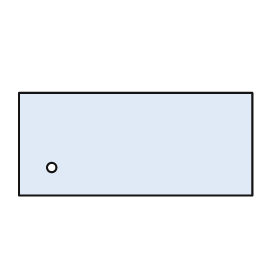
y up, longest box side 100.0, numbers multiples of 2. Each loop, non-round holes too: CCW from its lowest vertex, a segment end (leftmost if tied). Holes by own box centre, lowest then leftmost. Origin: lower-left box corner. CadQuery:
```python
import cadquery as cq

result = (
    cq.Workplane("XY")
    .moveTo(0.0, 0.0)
    .lineTo(100.0, 0.0)
    .lineTo(100.0, 44.0)
    .lineTo(0.0, 44.0)
    .close()
    .moveTo(14.0, 12.0)
    .circle(2.0)
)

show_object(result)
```